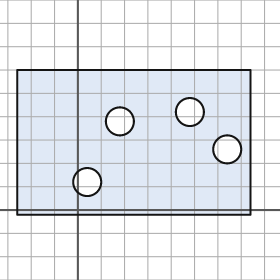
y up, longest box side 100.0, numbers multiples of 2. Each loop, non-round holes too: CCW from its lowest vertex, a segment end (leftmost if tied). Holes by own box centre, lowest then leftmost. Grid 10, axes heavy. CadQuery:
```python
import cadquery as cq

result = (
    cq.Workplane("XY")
    .moveTo(-26.0, -2.0)
    .lineTo(74.0, -2.0)
    .lineTo(74.0, 60.0)
    .lineTo(-26.0, 60.0)
    .close()
    .moveTo(4.0, 12.0)
    .circle(6.0)
    .moveTo(64.0, 26.0)
    .circle(6.0)
    .moveTo(18.0, 38.0)
    .circle(6.0)
    .moveTo(48.0, 42.0)
    .circle(6.0)
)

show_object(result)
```